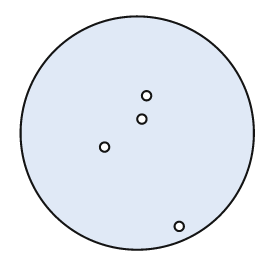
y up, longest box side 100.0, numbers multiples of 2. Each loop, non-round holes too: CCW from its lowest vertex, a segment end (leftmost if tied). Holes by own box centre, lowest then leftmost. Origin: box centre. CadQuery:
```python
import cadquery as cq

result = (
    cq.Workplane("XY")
    .moveTo(0.0, 0.0)
    .circle(50.0)
    .moveTo(18.0, -40.0)
    .circle(2.0)
    .moveTo(-14.0, -6.0)
    .circle(2.0)
    .moveTo(2.0, 6.0)
    .circle(2.0)
    .moveTo(4.0, 16.0)
    .circle(2.0)
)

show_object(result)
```